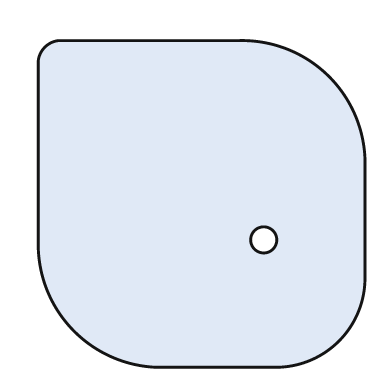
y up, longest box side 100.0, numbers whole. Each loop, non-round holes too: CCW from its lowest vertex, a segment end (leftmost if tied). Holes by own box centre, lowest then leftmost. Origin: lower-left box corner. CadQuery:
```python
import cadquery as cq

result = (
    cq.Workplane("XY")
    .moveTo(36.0, 0.0)
    .lineTo(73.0, 0.0)
    .threePointArc((92.0, 8.0), (100.0, 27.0))
    .lineTo(100.0, 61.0)
    .threePointArc((89.0, 89.0), (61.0, 100.0))
    .lineTo(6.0, 100.0)
    .threePointArc((2.0, 98.0), (0.0, 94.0))
    .lineTo(0.0, 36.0)
    .threePointArc((11.0, 11.0), (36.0, 0.0))
    .close()
    .moveTo(69.0, 39.0)
    .circle(4.0)
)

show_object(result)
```